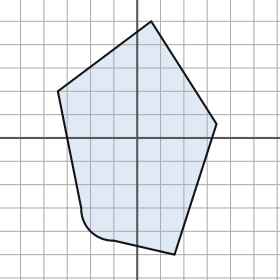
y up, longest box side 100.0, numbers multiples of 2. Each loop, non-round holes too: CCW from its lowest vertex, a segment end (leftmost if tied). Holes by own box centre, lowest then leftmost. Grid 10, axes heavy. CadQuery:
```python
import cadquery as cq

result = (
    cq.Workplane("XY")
    .moveTo(16.0, -50.0)
    .lineTo(34.0, 6.0)
    .lineTo(6.0, 50.0)
    .lineTo(-34.0, 20.0)
    .lineTo(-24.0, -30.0)
    .threePointArc((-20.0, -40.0), (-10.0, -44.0))
    .close()
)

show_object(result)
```